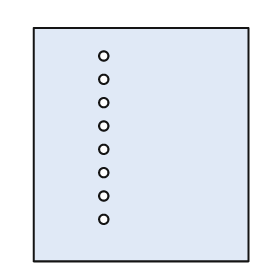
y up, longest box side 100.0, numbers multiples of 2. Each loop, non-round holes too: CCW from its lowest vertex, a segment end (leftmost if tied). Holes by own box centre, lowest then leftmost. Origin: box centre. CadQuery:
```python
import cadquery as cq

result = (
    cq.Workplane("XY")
    .moveTo(-46.0, -50.0)
    .lineTo(46.0, -50.0)
    .lineTo(46.0, 50.0)
    .lineTo(-46.0, 50.0)
    .close()
    .moveTo(-16.0, -32.0)
    .circle(2.0)
    .moveTo(-16.0, -22.0)
    .circle(2.0)
    .moveTo(-16.0, -12.0)
    .circle(2.0)
    .moveTo(-16.0, -2.0)
    .circle(2.0)
    .moveTo(-16.0, 8.0)
    .circle(2.0)
    .moveTo(-16.0, 18.0)
    .circle(2.0)
    .moveTo(-16.0, 28.0)
    .circle(2.0)
    .moveTo(-16.0, 38.0)
    .circle(2.0)
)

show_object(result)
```